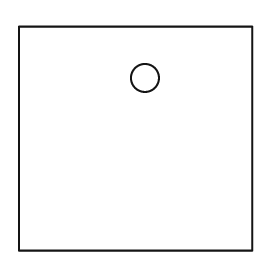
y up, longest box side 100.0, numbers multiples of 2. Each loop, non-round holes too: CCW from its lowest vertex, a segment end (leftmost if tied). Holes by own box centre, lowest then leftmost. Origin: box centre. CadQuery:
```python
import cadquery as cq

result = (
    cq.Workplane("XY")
    .moveTo(-50.0, -48.0)
    .lineTo(50.0, -48.0)
    .lineTo(50.0, 48.0)
    .lineTo(-50.0, 48.0)
    .close()
    .moveTo(4.0, 26.0)
    .circle(6.0)
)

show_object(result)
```